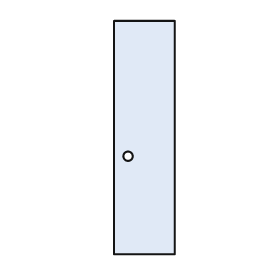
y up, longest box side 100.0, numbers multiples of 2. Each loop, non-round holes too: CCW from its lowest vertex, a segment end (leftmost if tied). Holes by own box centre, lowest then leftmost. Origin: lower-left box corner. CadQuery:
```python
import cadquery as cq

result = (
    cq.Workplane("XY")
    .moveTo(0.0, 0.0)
    .lineTo(26.0, 0.0)
    .lineTo(26.0, 100.0)
    .lineTo(0.0, 100.0)
    .close()
    .moveTo(6.0, 42.0)
    .circle(2.0)
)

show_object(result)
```